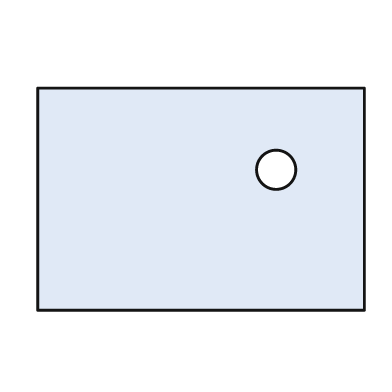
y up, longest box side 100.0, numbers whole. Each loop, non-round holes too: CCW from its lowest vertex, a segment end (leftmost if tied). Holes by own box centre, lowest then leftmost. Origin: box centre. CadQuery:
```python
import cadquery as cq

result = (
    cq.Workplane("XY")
    .moveTo(-50.0, -34.0)
    .lineTo(50.0, -34.0)
    .lineTo(50.0, 34.0)
    .lineTo(-50.0, 34.0)
    .close()
    .moveTo(23.0, 9.0)
    .circle(6.0)
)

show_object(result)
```